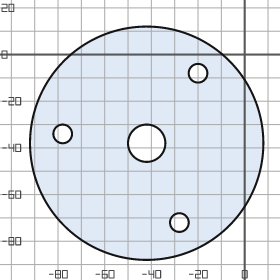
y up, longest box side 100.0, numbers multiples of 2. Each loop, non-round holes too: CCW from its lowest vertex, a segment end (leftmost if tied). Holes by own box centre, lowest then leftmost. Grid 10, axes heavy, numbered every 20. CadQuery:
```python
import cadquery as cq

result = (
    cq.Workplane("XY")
    .moveTo(-42.0, -38.0)
    .circle(50.0)
    .moveTo(-28.0, -72.0)
    .circle(4.0)
    .moveTo(-42.0, -38.0)
    .circle(8.0)
    .moveTo(-78.0, -34.0)
    .circle(4.0)
    .moveTo(-20.0, -8.0)
    .circle(4.0)
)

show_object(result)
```